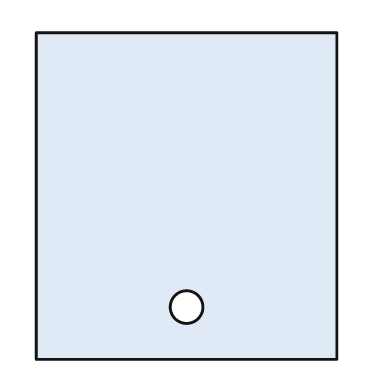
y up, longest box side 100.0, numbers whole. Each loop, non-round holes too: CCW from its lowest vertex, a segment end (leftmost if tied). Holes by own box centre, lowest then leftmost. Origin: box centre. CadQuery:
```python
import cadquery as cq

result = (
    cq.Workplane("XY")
    .moveTo(-46.0, -50.0)
    .lineTo(46.0, -50.0)
    .lineTo(46.0, 50.0)
    .lineTo(-46.0, 50.0)
    .close()
    .moveTo(0.0, -34.0)
    .circle(5.0)
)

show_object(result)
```